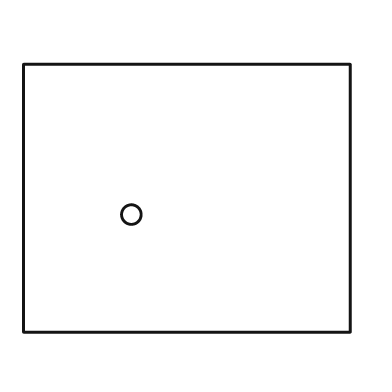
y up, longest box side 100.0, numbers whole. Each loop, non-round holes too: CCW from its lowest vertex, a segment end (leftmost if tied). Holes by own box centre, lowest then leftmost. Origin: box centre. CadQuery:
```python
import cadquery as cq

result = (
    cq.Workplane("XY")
    .moveTo(-50.0, -41.0)
    .lineTo(50.0, -41.0)
    .lineTo(50.0, 41.0)
    .lineTo(-50.0, 41.0)
    .close()
    .moveTo(-17.0, -5.0)
    .circle(3.0)
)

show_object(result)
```